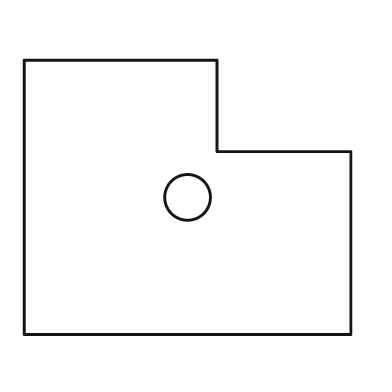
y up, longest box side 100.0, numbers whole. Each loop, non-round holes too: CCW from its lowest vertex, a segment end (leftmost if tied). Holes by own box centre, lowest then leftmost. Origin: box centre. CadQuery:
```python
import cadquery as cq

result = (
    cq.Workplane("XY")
    .moveTo(-50.0, -42.0)
    .lineTo(50.0, -42.0)
    .lineTo(50.0, 14.0)
    .lineTo(9.0, 14.0)
    .lineTo(9.0, 42.0)
    .lineTo(-50.0, 42.0)
    .close()
    .moveTo(0.0, 0.0)
    .circle(7.0)
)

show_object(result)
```